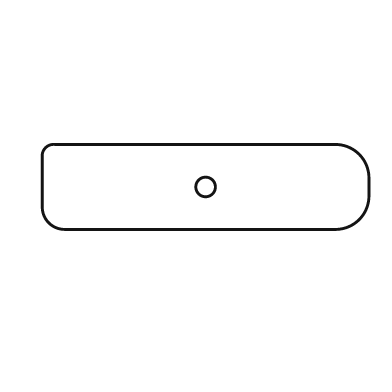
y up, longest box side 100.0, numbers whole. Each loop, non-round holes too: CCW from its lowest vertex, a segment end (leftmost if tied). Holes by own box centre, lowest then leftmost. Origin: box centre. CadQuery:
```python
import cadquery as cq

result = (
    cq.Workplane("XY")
    .moveTo(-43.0, -13.0)
    .lineTo(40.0, -13.0)
    .threePointArc((47.0, -10.0), (50.0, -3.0))
    .lineTo(50.0, 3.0)
    .threePointArc((47.0, 10.0), (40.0, 13.0))
    .lineTo(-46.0, 13.0)
    .threePointArc((-49.0, 12.0), (-50.0, 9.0))
    .lineTo(-50.0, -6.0)
    .threePointArc((-48.0, -11.0), (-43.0, -13.0))
    .close()
    .moveTo(0.0, 0.0)
    .circle(3.0)
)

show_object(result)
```